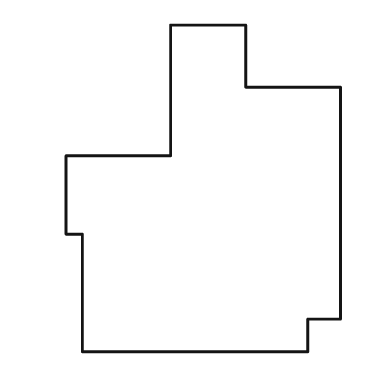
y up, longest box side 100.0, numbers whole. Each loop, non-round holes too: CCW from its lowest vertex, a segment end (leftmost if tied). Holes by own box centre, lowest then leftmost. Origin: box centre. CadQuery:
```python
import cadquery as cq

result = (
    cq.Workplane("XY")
    .moveTo(-37.0, -50.0)
    .lineTo(32.0, -50.0)
    .lineTo(32.0, -40.0)
    .lineTo(42.0, -40.0)
    .lineTo(42.0, 31.0)
    .lineTo(13.0, 31.0)
    .lineTo(13.0, 50.0)
    .lineTo(-10.0, 50.0)
    .lineTo(-10.0, 10.0)
    .lineTo(-42.0, 10.0)
    .lineTo(-42.0, -14.0)
    .lineTo(-37.0, -14.0)
    .close()
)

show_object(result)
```